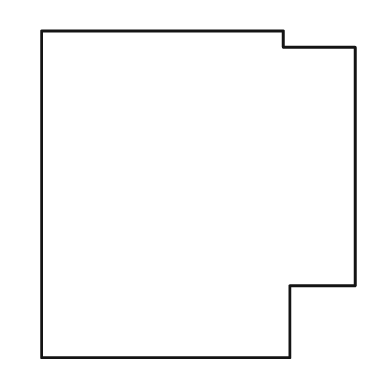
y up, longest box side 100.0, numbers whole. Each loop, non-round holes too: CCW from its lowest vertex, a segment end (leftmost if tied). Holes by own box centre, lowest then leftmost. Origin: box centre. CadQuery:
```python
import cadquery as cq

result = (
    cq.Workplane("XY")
    .moveTo(-48.0, -50.0)
    .lineTo(28.0, -50.0)
    .lineTo(28.0, -28.0)
    .lineTo(48.0, -28.0)
    .lineTo(48.0, 45.0)
    .lineTo(26.0, 45.0)
    .lineTo(26.0, 50.0)
    .lineTo(-48.0, 50.0)
    .close()
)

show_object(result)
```